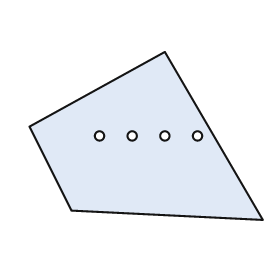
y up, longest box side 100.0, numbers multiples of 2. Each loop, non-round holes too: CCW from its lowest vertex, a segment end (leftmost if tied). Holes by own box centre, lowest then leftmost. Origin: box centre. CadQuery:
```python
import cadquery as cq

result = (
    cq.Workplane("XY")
    .moveTo(50.0, -36.0)
    .lineTo(8.0, 36.0)
    .lineTo(-50.0, 4.0)
    .lineTo(-32.0, -32.0)
    .close()
    .moveTo(-20.0, 0.0)
    .circle(2.0)
    .moveTo(-6.0, 0.0)
    .circle(2.0)
    .moveTo(8.0, 0.0)
    .circle(2.0)
    .moveTo(22.0, 0.0)
    .circle(2.0)
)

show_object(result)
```